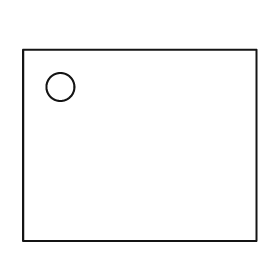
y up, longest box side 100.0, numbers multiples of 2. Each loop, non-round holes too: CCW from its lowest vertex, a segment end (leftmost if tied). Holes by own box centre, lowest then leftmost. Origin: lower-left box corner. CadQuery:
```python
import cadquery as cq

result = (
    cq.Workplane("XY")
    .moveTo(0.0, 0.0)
    .lineTo(100.0, 0.0)
    .lineTo(100.0, 82.0)
    .lineTo(0.0, 82.0)
    .close()
    .moveTo(16.0, 66.0)
    .circle(6.0)
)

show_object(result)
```